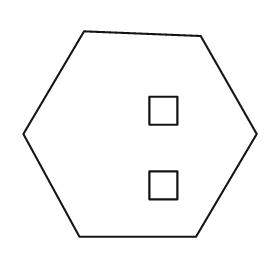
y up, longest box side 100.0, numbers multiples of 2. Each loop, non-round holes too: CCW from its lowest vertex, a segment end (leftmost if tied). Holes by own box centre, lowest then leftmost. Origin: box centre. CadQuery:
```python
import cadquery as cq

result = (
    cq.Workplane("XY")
    .moveTo(-26.0, -44.0)
    .lineTo(24.0, -44.0)
    .lineTo(50.0, 0.0)
    .lineTo(26.0, 42.0)
    .lineTo(-24.0, 44.0)
    .lineTo(-50.0, 0.0)
    .close()
    .moveTo(4.0, -28.0)
    .lineTo(16.0, -28.0)
    .lineTo(16.0, -16.0)
    .lineTo(4.0, -16.0)
    .close()
    .moveTo(4.0, 4.0)
    .lineTo(16.0, 4.0)
    .lineTo(16.0, 16.0)
    .lineTo(4.0, 16.0)
    .close()
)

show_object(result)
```